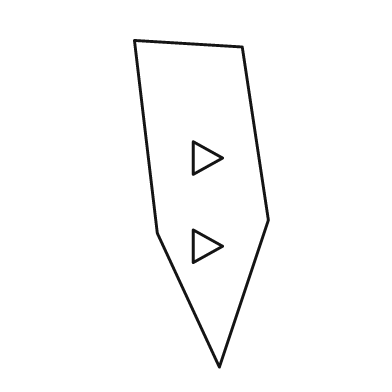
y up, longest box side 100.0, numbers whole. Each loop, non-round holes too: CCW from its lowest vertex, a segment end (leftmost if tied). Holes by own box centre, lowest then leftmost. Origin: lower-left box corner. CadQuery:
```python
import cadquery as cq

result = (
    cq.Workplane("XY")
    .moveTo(26.0, 0.0)
    .lineTo(41.0, 45.0)
    .lineTo(33.0, 98.0)
    .lineTo(0.0, 100.0)
    .lineTo(7.0, 41.0)
    .close()
    .moveTo(18.0, 32.0)
    .lineTo(27.0, 37.0)
    .lineTo(18.0, 42.0)
    .close()
    .moveTo(18.0, 59.0)
    .lineTo(27.0, 64.0)
    .lineTo(18.0, 69.0)
    .close()
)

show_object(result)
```